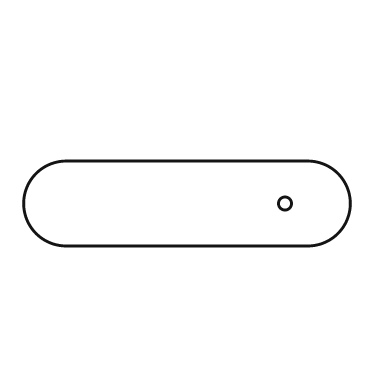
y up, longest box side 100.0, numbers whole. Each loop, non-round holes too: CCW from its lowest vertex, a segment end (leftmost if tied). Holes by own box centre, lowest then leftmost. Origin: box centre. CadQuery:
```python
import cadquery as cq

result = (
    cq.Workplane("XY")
    .moveTo(-37.0, -13.0)
    .lineTo(37.0, -13.0)
    .threePointArc((50.0, 0.0), (37.0, 13.0))
    .lineTo(-37.0, 13.0)
    .threePointArc((-50.0, 0.0), (-37.0, -13.0))
    .close()
    .moveTo(30.0, 0.0)
    .circle(2.0)
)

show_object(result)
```